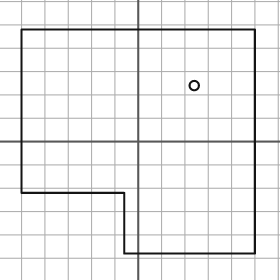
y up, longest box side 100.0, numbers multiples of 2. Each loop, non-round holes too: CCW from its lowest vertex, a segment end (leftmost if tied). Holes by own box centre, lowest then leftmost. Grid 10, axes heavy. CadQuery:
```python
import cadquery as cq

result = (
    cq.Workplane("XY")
    .moveTo(-6.0, -48.0)
    .lineTo(50.0, -48.0)
    .lineTo(50.0, 48.0)
    .lineTo(-50.0, 48.0)
    .lineTo(-50.0, -22.0)
    .lineTo(-6.0, -22.0)
    .close()
    .moveTo(24.0, 24.0)
    .circle(2.0)
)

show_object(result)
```